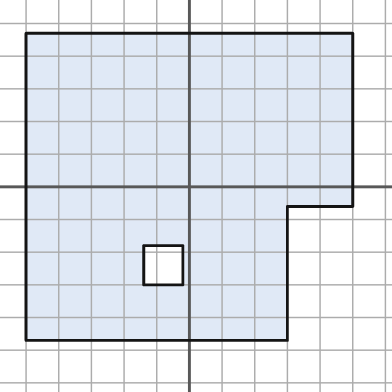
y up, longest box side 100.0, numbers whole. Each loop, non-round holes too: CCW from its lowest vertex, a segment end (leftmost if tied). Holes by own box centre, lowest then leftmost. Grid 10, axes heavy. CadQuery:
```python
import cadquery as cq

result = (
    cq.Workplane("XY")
    .moveTo(-50.0, -47.0)
    .lineTo(30.0, -47.0)
    .lineTo(30.0, -6.0)
    .lineTo(50.0, -6.0)
    .lineTo(50.0, 47.0)
    .lineTo(-50.0, 47.0)
    .close()
    .moveTo(-14.0, -30.0)
    .lineTo(-2.0, -30.0)
    .lineTo(-2.0, -18.0)
    .lineTo(-14.0, -18.0)
    .close()
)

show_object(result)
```